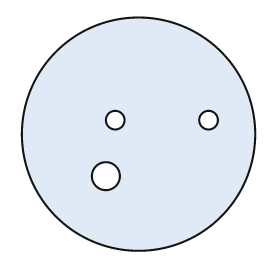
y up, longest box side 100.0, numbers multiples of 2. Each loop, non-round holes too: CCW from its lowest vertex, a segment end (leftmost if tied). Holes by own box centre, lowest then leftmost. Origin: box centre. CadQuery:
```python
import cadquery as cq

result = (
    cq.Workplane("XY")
    .moveTo(0.0, 0.0)
    .circle(50.0)
    .moveTo(-14.0, -18.0)
    .circle(6.0)
    .moveTo(-10.0, 6.0)
    .circle(4.0)
    .moveTo(30.0, 6.0)
    .circle(4.0)
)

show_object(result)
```